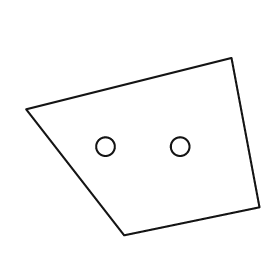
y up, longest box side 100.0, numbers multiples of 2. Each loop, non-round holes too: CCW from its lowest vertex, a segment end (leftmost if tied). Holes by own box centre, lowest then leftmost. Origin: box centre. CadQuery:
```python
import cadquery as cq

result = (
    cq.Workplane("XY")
    .moveTo(-8.0, -38.0)
    .lineTo(50.0, -26.0)
    .lineTo(38.0, 38.0)
    .lineTo(-50.0, 16.0)
    .close()
    .moveTo(-16.0, 0.0)
    .circle(4.0)
    .moveTo(16.0, 0.0)
    .circle(4.0)
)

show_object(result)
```